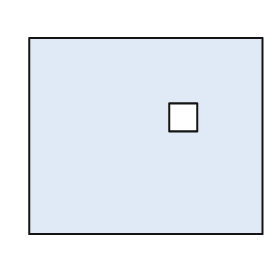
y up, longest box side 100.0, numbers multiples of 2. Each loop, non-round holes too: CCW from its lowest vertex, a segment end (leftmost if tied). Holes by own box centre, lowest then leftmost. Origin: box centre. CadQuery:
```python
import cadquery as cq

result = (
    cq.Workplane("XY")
    .moveTo(-50.0, -42.0)
    .lineTo(50.0, -42.0)
    .lineTo(50.0, 42.0)
    .lineTo(-50.0, 42.0)
    .close()
    .moveTo(10.0, 2.0)
    .lineTo(22.0, 2.0)
    .lineTo(22.0, 14.0)
    .lineTo(10.0, 14.0)
    .close()
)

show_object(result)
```